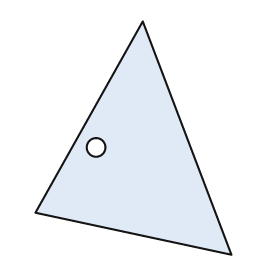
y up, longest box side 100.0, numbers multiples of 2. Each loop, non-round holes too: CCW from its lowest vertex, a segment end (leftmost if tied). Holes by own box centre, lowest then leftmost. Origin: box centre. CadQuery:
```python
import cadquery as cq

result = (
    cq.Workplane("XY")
    .moveTo(42.0, -50.0)
    .lineTo(4.0, 50.0)
    .lineTo(-42.0, -32.0)
    .close()
    .moveTo(-16.0, -4.0)
    .circle(4.0)
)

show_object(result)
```